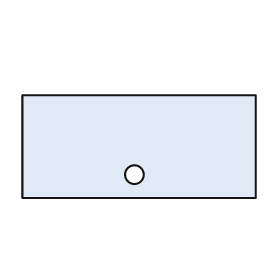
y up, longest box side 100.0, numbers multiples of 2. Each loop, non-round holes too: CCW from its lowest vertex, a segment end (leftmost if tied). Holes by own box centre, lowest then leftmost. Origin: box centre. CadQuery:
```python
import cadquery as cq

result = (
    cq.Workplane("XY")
    .moveTo(-50.0, -22.0)
    .lineTo(50.0, -22.0)
    .lineTo(50.0, 22.0)
    .lineTo(-50.0, 22.0)
    .close()
    .moveTo(-2.0, -12.0)
    .circle(4.0)
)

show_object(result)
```